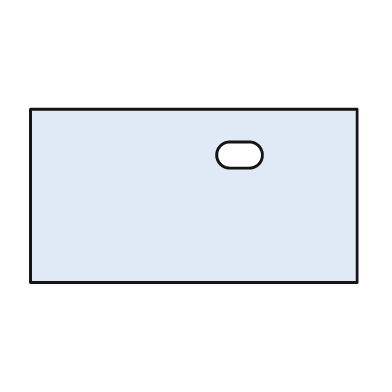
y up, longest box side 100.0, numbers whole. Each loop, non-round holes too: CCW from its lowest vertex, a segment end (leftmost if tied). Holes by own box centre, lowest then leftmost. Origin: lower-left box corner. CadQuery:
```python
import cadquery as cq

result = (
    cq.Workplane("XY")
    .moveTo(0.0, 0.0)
    .lineTo(100.0, 0.0)
    .lineTo(100.0, 53.0)
    .lineTo(0.0, 53.0)
    .close()
    .moveTo(61.0, 35.0)
    .lineTo(67.0, 35.0)
    .threePointArc((71.0, 39.0), (67.0, 43.0))
    .lineTo(61.0, 43.0)
    .threePointArc((57.0, 39.0), (61.0, 35.0))
    .close()
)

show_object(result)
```